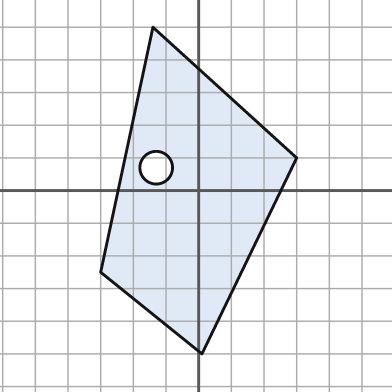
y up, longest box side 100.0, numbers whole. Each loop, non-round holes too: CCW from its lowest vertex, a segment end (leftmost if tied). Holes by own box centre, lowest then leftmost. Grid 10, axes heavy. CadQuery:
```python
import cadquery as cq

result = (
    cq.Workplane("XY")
    .moveTo(1.0, -50.0)
    .lineTo(30.0, 10.0)
    .lineTo(-14.0, 50.0)
    .lineTo(-30.0, -25.0)
    .close()
    .moveTo(-13.0, 7.0)
    .circle(5.0)
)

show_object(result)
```